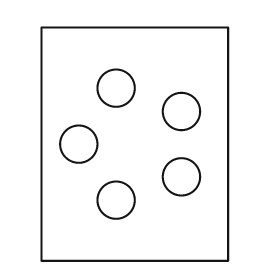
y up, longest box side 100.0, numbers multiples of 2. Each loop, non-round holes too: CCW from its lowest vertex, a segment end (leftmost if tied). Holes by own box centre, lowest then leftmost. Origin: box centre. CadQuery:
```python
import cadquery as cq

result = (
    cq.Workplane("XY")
    .moveTo(-40.0, -50.0)
    .lineTo(40.0, -50.0)
    .lineTo(40.0, 50.0)
    .lineTo(-40.0, 50.0)
    .close()
    .moveTo(-8.0, -24.0)
    .circle(8.0)
    .moveTo(20.0, -14.0)
    .circle(8.0)
    .moveTo(-24.0, 0.0)
    .circle(8.0)
    .moveTo(20.0, 14.0)
    .circle(8.0)
    .moveTo(-8.0, 24.0)
    .circle(8.0)
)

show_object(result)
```